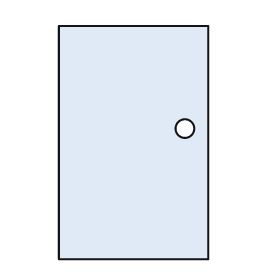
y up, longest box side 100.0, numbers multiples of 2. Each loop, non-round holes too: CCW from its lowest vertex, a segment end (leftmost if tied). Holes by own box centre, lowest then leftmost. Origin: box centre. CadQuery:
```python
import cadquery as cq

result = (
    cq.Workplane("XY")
    .moveTo(-32.0, -50.0)
    .lineTo(32.0, -50.0)
    .lineTo(32.0, 50.0)
    .lineTo(-32.0, 50.0)
    .close()
    .moveTo(22.0, 6.0)
    .circle(4.0)
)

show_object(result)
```